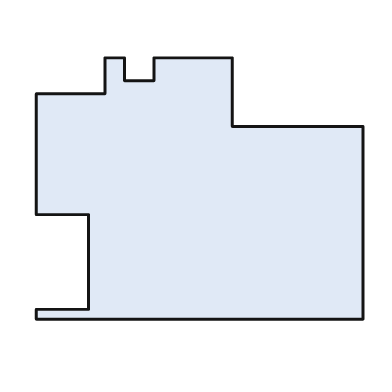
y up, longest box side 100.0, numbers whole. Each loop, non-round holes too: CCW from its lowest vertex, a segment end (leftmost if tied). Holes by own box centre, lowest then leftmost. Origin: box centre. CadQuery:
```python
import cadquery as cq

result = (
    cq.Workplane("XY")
    .moveTo(-50.0, -40.0)
    .lineTo(50.0, -40.0)
    .lineTo(50.0, 19.0)
    .lineTo(10.0, 19.0)
    .lineTo(10.0, 40.0)
    .lineTo(-14.0, 40.0)
    .lineTo(-14.0, 33.0)
    .lineTo(-23.0, 33.0)
    .lineTo(-23.0, 40.0)
    .lineTo(-29.0, 40.0)
    .lineTo(-29.0, 29.0)
    .lineTo(-50.0, 29.0)
    .lineTo(-50.0, -8.0)
    .lineTo(-34.0, -8.0)
    .lineTo(-34.0, -37.0)
    .lineTo(-50.0, -37.0)
    .close()
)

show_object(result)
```